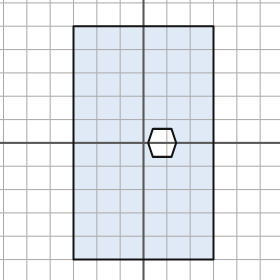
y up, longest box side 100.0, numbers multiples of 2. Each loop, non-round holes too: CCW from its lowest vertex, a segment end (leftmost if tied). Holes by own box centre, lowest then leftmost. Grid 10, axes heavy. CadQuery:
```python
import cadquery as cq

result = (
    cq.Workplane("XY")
    .moveTo(-30.0, -50.0)
    .lineTo(30.0, -50.0)
    .lineTo(30.0, 50.0)
    .lineTo(-30.0, 50.0)
    .close()
    .moveTo(4.0, -6.0)
    .lineTo(12.0, -6.0)
    .lineTo(14.0, 0.0)
    .lineTo(12.0, 6.0)
    .lineTo(4.0, 6.0)
    .lineTo(2.0, 0.0)
    .close()
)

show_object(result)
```